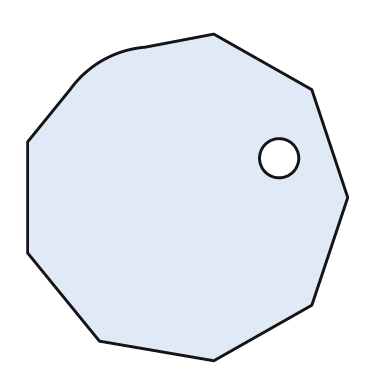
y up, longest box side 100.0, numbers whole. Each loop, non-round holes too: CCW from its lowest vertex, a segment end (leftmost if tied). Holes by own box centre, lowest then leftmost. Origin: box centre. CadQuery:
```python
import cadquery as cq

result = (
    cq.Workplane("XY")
    .moveTo(8.0, -50.0)
    .lineTo(38.0, -33.0)
    .lineTo(49.0, 0.0)
    .lineTo(38.0, 33.0)
    .lineTo(8.0, 50.0)
    .lineTo(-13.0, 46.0)
    .threePointArc((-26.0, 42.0), (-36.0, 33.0))
    .lineTo(-49.0, 17.0)
    .lineTo(-49.0, -17.0)
    .lineTo(-27.0, -44.0)
    .close()
    .moveTo(28.0, 12.0)
    .circle(6.0)
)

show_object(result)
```